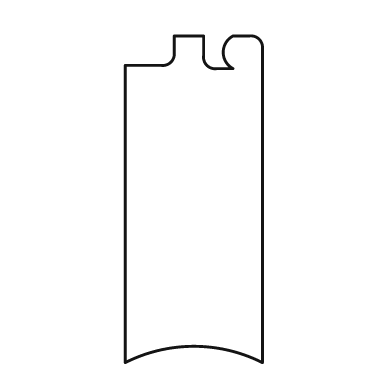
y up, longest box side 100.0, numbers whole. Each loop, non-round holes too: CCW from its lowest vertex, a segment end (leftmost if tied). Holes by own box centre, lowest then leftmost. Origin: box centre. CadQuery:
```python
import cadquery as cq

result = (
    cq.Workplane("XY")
    .moveTo(-21.0, -50.0)
    .threePointArc((0.0, -45.0), (21.0, -50.0))
    .lineTo(21.0, 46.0)
    .threePointArc((20.0, 49.0), (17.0, 50.0))
    .lineTo(12.0, 50.0)
    .threePointArc((9.0, 45.0), (12.0, 40.0))
    .lineTo(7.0, 40.0)
    .threePointArc((4.0, 41.0), (3.0, 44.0))
    .lineTo(3.0, 50.0)
    .lineTo(-6.0, 50.0)
    .lineTo(-6.0, 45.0)
    .threePointArc((-7.0, 42.0), (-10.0, 41.0))
    .lineTo(-21.0, 41.0)
    .close()
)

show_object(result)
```